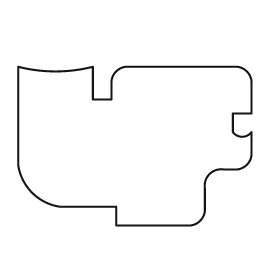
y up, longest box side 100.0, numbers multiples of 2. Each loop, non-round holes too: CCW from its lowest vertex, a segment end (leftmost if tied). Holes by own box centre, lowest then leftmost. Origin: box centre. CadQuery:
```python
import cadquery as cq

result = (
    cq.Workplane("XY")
    .moveTo(-8.0, -34.0)
    .lineTo(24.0, -34.0)
    .threePointArc((28.0, -32.0), (30.0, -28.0))
    .lineTo(30.0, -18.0)
    .threePointArc((32.0, -12.0), (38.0, -10.0))
    .lineTo(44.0, -10.0)
    .threePointArc((48.0, -8.0), (50.0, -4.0))
    .lineTo(50.0, 6.0)
    .threePointArc((46.0, 4.0), (42.0, 6.0))
    .lineTo(42.0, 14.0)
    .lineTo(50.0, 14.0)
    .lineTo(50.0, 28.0)
    .threePointArc((48.0, 32.0), (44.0, 34.0))
    .lineTo(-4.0, 34.0)
    .threePointArc((-8.0, 32.0), (-10.0, 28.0))
    .lineTo(-10.0, 20.0)
    .lineTo(-18.0, 20.0)
    .lineTo(-18.0, 34.0)
    .threePointArc((-34.0, 32.0), (-50.0, 34.0))
    .lineTo(-50.0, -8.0)
    .threePointArc((-44.0, -20.0), (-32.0, -26.0))
    .lineTo(-8.0, -26.0)
    .close()
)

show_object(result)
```